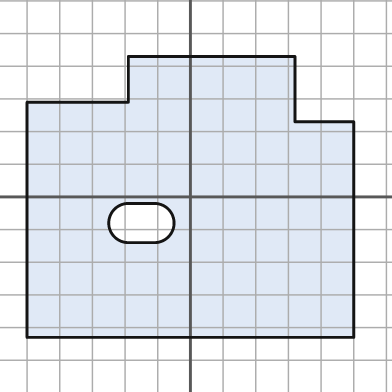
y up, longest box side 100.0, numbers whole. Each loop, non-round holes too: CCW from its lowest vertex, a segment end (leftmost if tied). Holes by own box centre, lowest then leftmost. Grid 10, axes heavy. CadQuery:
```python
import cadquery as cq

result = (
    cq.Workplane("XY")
    .moveTo(-50.0, -43.0)
    .lineTo(50.0, -43.0)
    .lineTo(50.0, 23.0)
    .lineTo(32.0, 23.0)
    .lineTo(32.0, 43.0)
    .lineTo(-19.0, 43.0)
    .lineTo(-19.0, 29.0)
    .lineTo(-50.0, 29.0)
    .close()
    .moveTo(-19.0, -14.0)
    .lineTo(-11.0, -14.0)
    .threePointArc((-5.0, -8.0), (-11.0, -2.0))
    .lineTo(-19.0, -2.0)
    .threePointArc((-25.0, -8.0), (-19.0, -14.0))
    .close()
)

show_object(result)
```